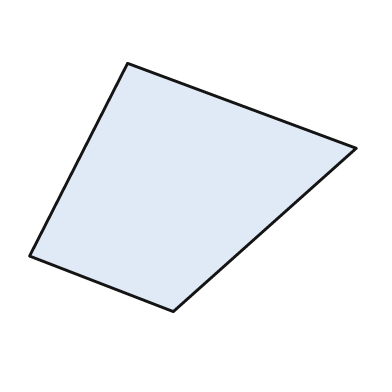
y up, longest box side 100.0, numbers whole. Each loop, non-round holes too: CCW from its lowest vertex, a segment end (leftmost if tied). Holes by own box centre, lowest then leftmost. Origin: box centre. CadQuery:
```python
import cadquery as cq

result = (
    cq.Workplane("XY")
    .moveTo(-6.0, -38.0)
    .lineTo(50.0, 12.0)
    .lineTo(-20.0, 38.0)
    .lineTo(-50.0, -21.0)
    .close()
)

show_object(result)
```